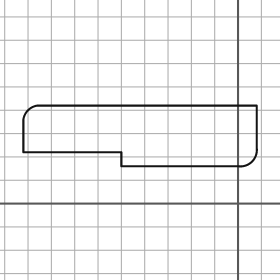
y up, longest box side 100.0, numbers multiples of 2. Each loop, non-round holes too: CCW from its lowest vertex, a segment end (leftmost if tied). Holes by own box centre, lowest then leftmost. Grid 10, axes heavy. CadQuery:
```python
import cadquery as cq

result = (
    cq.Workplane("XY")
    .moveTo(-50.0, 16.0)
    .lineTo(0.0, 16.0)
    .threePointArc((6.0, 18.0), (8.0, 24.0))
    .lineTo(8.0, 42.0)
    .lineTo(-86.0, 42.0)
    .threePointArc((-90.0, 40.0), (-92.0, 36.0))
    .lineTo(-92.0, 22.0)
    .lineTo(-50.0, 22.0)
    .close()
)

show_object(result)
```